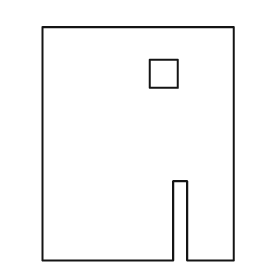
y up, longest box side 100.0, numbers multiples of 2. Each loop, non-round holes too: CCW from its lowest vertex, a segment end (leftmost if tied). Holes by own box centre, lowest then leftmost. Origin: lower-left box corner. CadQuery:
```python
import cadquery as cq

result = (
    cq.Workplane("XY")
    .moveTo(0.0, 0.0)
    .lineTo(56.0, 0.0)
    .lineTo(56.0, 34.0)
    .lineTo(62.0, 34.0)
    .lineTo(62.0, 0.0)
    .lineTo(82.0, 0.0)
    .lineTo(82.0, 100.0)
    .lineTo(0.0, 100.0)
    .close()
    .moveTo(46.0, 74.0)
    .lineTo(58.0, 74.0)
    .lineTo(58.0, 86.0)
    .lineTo(46.0, 86.0)
    .close()
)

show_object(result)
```